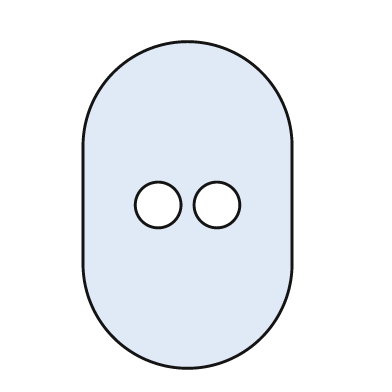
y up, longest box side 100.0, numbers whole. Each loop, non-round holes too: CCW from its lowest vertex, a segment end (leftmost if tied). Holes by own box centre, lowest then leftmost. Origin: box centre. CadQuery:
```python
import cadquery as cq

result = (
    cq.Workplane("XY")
    .moveTo(-32.0, -18.0)
    .threePointArc((0.0, -50.0), (32.0, -18.0))
    .lineTo(32.0, 18.0)
    .threePointArc((0.0, 50.0), (-32.0, 18.0))
    .close()
    .moveTo(-9.0, 0.0)
    .circle(7.0)
    .moveTo(9.0, 0.0)
    .circle(7.0)
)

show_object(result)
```